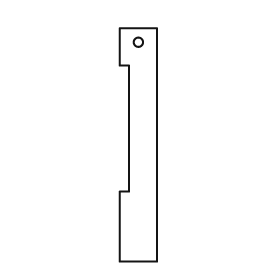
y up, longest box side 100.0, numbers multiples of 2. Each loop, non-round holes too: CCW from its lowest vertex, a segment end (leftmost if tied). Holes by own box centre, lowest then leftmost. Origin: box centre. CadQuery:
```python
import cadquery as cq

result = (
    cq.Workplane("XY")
    .moveTo(-8.0, -50.0)
    .lineTo(8.0, -50.0)
    .lineTo(8.0, 50.0)
    .lineTo(-8.0, 50.0)
    .lineTo(-8.0, 34.0)
    .lineTo(-4.0, 34.0)
    .lineTo(-4.0, -20.0)
    .lineTo(-8.0, -20.0)
    .close()
    .moveTo(0.0, 44.0)
    .circle(2.0)
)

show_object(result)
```